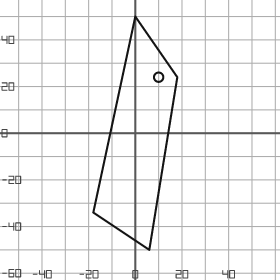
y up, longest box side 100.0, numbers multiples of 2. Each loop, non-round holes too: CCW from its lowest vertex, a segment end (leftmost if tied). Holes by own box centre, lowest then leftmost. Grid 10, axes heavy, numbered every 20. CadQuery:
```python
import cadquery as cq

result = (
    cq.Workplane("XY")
    .moveTo(6.0, -50.0)
    .lineTo(18.0, 24.0)
    .lineTo(0.0, 50.0)
    .lineTo(-18.0, -34.0)
    .close()
    .moveTo(10.0, 24.0)
    .circle(2.0)
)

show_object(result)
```